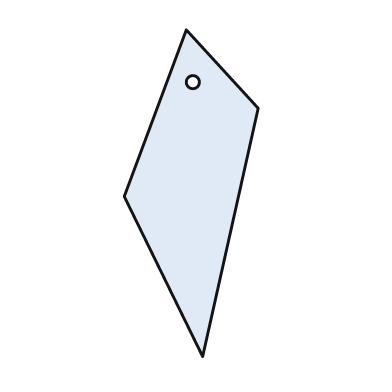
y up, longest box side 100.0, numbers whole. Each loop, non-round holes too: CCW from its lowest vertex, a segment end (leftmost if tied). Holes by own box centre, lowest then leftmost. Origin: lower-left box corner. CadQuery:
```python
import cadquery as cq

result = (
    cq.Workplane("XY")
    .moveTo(24.0, 0.0)
    .lineTo(41.0, 76.0)
    .lineTo(19.0, 100.0)
    .lineTo(0.0, 49.0)
    .close()
    .moveTo(21.0, 84.0)
    .circle(2.0)
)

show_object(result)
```